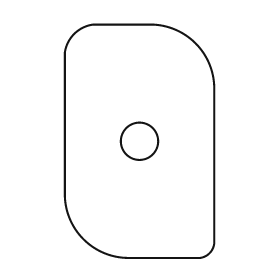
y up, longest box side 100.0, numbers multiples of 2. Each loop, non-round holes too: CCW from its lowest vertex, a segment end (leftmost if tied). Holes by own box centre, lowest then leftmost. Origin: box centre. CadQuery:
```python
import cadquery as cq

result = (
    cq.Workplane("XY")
    .moveTo(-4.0, -50.0)
    .lineTo(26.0, -50.0)
    .threePointArc((30.0, -48.0), (32.0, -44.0))
    .lineTo(32.0, 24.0)
    .threePointArc((24.0, 42.0), (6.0, 50.0))
    .lineTo(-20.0, 50.0)
    .threePointArc((-28.0, 46.0), (-32.0, 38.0))
    .lineTo(-32.0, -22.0)
    .threePointArc((-24.0, -42.0), (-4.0, -50.0))
    .close()
    .moveTo(0.0, 0.0)
    .circle(8.0)
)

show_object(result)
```